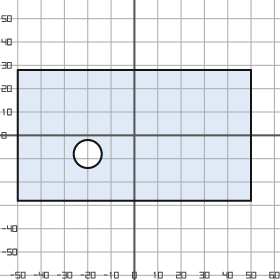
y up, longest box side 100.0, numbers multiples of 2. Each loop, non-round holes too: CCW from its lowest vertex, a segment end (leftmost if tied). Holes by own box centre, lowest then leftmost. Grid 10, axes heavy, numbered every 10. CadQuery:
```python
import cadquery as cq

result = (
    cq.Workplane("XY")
    .moveTo(-50.0, -28.0)
    .lineTo(50.0, -28.0)
    .lineTo(50.0, 28.0)
    .lineTo(-50.0, 28.0)
    .close()
    .moveTo(-20.0, -8.0)
    .circle(6.0)
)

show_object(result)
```